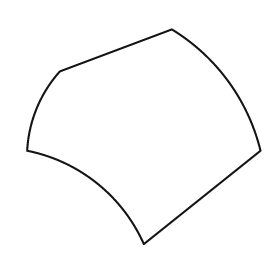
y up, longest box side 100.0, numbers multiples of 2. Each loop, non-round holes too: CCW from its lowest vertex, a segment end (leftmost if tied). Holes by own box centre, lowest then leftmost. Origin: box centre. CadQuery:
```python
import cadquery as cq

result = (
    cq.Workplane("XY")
    .moveTo(0.0, -46.0)
    .lineTo(50.0, -6.0)
    .threePointArc((36.0, 24.0), (12.0, 46.0))
    .lineTo(-36.0, 28.0)
    .threePointArc((-46.0, 12.0), (-50.0, -6.0))
    .threePointArc((-20.0, -20.0), (0.0, -46.0))
    .close()
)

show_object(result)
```